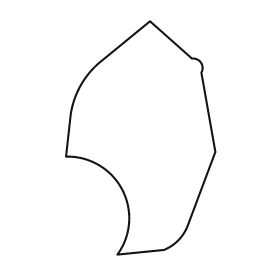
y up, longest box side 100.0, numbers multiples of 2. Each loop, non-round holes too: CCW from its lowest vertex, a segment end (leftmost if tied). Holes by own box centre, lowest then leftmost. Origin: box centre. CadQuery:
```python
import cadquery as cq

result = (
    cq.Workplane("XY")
    .moveTo(-10.0, -50.0)
    .lineTo(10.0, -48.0)
    .threePointArc((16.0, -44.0), (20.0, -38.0))
    .lineTo(32.0, -6.0)
    .lineTo(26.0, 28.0)
    .threePointArc((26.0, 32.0), (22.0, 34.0))
    .lineTo(4.0, 50.0)
    .lineTo(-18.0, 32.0)
    .threePointArc((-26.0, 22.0), (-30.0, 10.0))
    .lineTo(-32.0, -8.0)
    .threePointArc((-8.0, -22.0), (-10.0, -50.0))
    .close()
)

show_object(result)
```